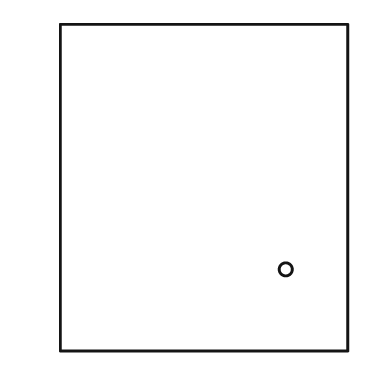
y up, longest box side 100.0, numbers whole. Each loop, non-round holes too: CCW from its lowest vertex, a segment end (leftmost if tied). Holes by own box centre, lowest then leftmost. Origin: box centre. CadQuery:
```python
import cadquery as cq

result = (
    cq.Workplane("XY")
    .moveTo(-44.0, -50.0)
    .lineTo(44.0, -50.0)
    .lineTo(44.0, 50.0)
    .lineTo(-44.0, 50.0)
    .close()
    .moveTo(25.0, -25.0)
    .circle(2.0)
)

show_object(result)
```